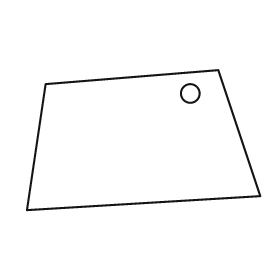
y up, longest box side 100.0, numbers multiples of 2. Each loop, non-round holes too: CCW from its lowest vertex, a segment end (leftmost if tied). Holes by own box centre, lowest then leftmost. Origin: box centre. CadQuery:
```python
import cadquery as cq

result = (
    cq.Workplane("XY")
    .moveTo(-50.0, -30.0)
    .lineTo(50.0, -24.0)
    .lineTo(32.0, 30.0)
    .lineTo(-42.0, 24.0)
    .close()
    .moveTo(20.0, 20.0)
    .circle(4.0)
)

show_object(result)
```